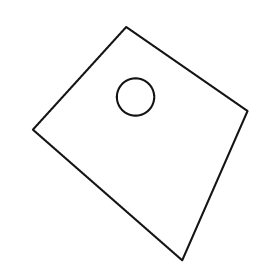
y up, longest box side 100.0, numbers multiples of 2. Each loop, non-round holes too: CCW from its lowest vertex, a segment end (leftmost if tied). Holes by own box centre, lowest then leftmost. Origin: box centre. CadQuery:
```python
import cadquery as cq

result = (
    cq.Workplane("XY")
    .moveTo(18.0, -50.0)
    .lineTo(46.0, 14.0)
    .lineTo(-6.0, 50.0)
    .lineTo(-46.0, 6.0)
    .close()
    .moveTo(-2.0, 20.0)
    .circle(8.0)
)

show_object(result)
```